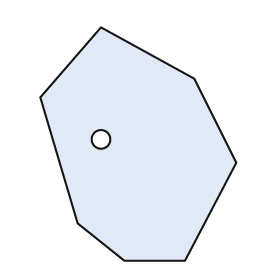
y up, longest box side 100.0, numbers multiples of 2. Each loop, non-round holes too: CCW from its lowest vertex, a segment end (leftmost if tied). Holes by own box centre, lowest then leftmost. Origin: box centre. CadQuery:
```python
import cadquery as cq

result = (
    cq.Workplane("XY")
    .moveTo(-6.0, -50.0)
    .lineTo(20.0, -50.0)
    .lineTo(42.0, -8.0)
    .lineTo(24.0, 28.0)
    .lineTo(-16.0, 50.0)
    .lineTo(-42.0, 20.0)
    .lineTo(-26.0, -34.0)
    .close()
    .moveTo(-16.0, 2.0)
    .circle(4.0)
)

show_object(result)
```